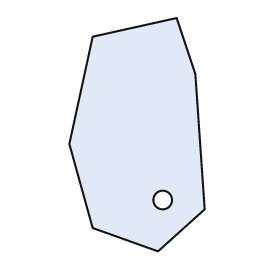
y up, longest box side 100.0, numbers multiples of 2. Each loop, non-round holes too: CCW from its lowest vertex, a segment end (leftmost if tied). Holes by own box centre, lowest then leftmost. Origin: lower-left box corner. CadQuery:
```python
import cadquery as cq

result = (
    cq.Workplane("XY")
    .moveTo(38.0, 0.0)
    .lineTo(58.0, 18.0)
    .lineTo(54.0, 76.0)
    .lineTo(46.0, 100.0)
    .lineTo(10.0, 92.0)
    .lineTo(0.0, 46.0)
    .lineTo(10.0, 10.0)
    .close()
    .moveTo(40.0, 22.0)
    .circle(4.0)
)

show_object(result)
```